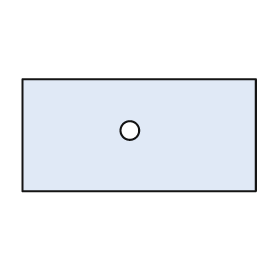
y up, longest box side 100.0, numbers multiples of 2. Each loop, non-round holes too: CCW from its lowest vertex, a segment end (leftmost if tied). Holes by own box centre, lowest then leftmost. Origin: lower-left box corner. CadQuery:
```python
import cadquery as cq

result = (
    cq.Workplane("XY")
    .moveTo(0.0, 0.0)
    .lineTo(100.0, 0.0)
    .lineTo(100.0, 48.0)
    .lineTo(0.0, 48.0)
    .close()
    .moveTo(46.0, 26.0)
    .circle(4.0)
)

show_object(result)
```